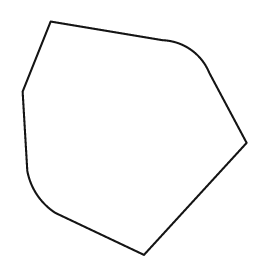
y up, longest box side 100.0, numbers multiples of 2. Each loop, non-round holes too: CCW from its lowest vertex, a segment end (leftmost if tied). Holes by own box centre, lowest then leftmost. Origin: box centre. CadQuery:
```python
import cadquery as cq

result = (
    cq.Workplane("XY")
    .moveTo(4.0, -50.0)
    .lineTo(48.0, -2.0)
    .lineTo(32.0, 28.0)
    .threePointArc((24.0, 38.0), (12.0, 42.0))
    .lineTo(-36.0, 50.0)
    .lineTo(-48.0, 20.0)
    .lineTo(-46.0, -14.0)
    .threePointArc((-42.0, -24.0), (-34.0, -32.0))
    .close()
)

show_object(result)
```